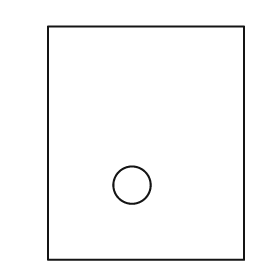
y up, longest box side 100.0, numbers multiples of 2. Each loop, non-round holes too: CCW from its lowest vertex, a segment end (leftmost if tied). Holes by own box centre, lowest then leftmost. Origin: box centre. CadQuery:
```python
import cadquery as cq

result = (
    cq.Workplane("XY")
    .moveTo(-42.0, -50.0)
    .lineTo(42.0, -50.0)
    .lineTo(42.0, 50.0)
    .lineTo(-42.0, 50.0)
    .close()
    .moveTo(-6.0, -18.0)
    .circle(8.0)
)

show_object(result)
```